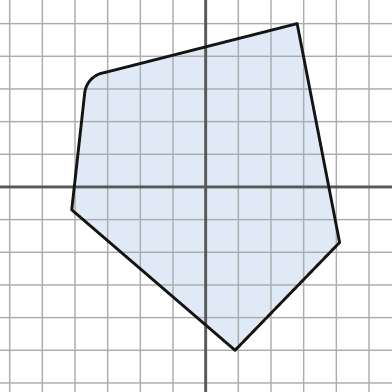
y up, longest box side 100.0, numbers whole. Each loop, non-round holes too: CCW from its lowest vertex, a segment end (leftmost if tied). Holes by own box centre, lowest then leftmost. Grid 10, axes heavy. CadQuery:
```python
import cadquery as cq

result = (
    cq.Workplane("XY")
    .moveTo(9.0, -50.0)
    .lineTo(41.0, -17.0)
    .lineTo(28.0, 50.0)
    .lineTo(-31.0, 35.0)
    .threePointArc((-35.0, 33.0), (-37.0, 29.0))
    .lineTo(-41.0, -7.0)
    .close()
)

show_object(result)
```